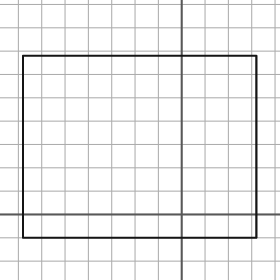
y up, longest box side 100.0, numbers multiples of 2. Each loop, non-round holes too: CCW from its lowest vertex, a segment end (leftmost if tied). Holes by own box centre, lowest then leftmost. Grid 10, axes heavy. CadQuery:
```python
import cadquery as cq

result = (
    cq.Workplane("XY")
    .moveTo(-68.0, -10.0)
    .lineTo(32.0, -10.0)
    .lineTo(32.0, 68.0)
    .lineTo(-68.0, 68.0)
    .close()
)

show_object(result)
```